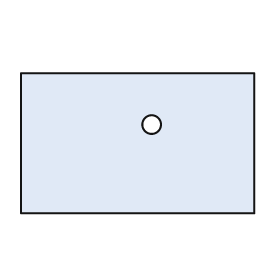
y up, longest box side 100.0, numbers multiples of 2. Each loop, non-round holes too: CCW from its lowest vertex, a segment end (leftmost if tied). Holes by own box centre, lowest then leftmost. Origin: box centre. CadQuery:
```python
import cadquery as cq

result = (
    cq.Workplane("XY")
    .moveTo(-50.0, -30.0)
    .lineTo(50.0, -30.0)
    .lineTo(50.0, 30.0)
    .lineTo(-50.0, 30.0)
    .close()
    .moveTo(6.0, 8.0)
    .circle(4.0)
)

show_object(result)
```